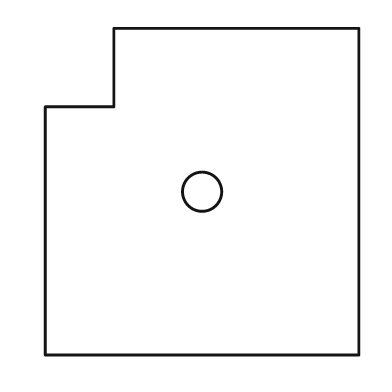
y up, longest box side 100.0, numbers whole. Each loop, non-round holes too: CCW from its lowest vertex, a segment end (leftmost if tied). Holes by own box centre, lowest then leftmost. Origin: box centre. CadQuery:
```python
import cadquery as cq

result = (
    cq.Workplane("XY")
    .moveTo(-48.0, -50.0)
    .lineTo(48.0, -50.0)
    .lineTo(48.0, 50.0)
    .lineTo(-27.0, 50.0)
    .lineTo(-27.0, 26.0)
    .lineTo(-48.0, 26.0)
    .close()
    .moveTo(0.0, 0.0)
    .circle(6.0)
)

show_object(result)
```